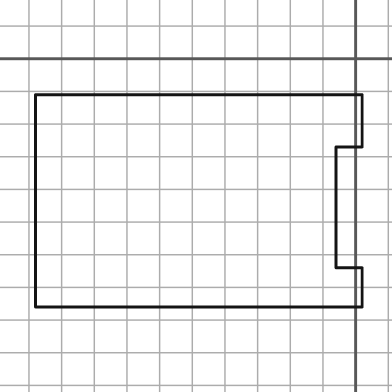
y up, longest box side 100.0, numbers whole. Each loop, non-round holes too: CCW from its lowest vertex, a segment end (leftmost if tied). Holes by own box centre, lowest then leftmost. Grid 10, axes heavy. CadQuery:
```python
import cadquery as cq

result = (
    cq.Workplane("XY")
    .moveTo(-98.0, -76.0)
    .lineTo(2.0, -76.0)
    .lineTo(2.0, -64.0)
    .lineTo(-6.0, -64.0)
    .lineTo(-6.0, -27.0)
    .lineTo(2.0, -27.0)
    .lineTo(2.0, -11.0)
    .lineTo(-98.0, -11.0)
    .close()
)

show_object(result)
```